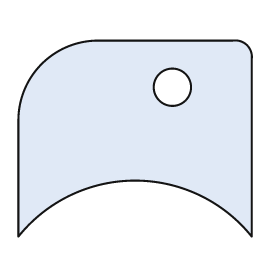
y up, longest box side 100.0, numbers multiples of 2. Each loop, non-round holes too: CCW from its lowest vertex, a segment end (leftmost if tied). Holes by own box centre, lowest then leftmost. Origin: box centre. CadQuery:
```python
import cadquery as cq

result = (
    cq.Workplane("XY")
    .moveTo(-50.0, -42.0)
    .threePointArc((0.0, -18.0), (50.0, -42.0))
    .lineTo(50.0, 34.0)
    .threePointArc((48.0, 40.0), (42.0, 42.0))
    .lineTo(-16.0, 42.0)
    .threePointArc((-40.0, 32.0), (-50.0, 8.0))
    .close()
    .moveTo(16.0, 22.0)
    .circle(8.0)
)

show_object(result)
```